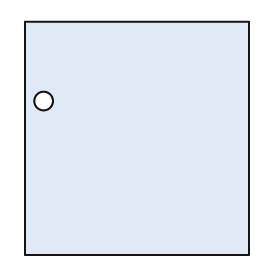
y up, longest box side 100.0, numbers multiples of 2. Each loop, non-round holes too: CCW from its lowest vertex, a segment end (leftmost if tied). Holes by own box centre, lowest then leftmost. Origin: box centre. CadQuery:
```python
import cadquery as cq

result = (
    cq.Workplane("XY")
    .moveTo(-48.0, -50.0)
    .lineTo(48.0, -50.0)
    .lineTo(48.0, 50.0)
    .lineTo(-48.0, 50.0)
    .close()
    .moveTo(-40.0, 16.0)
    .circle(4.0)
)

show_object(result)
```